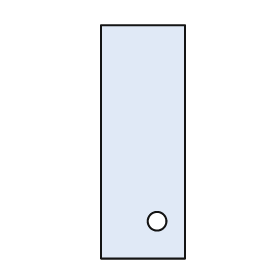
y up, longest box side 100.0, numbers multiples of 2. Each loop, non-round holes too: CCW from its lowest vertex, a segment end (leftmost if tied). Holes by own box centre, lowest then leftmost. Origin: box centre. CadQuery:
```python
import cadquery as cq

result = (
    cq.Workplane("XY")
    .moveTo(-18.0, -50.0)
    .lineTo(18.0, -50.0)
    .lineTo(18.0, 50.0)
    .lineTo(-18.0, 50.0)
    .close()
    .moveTo(6.0, -34.0)
    .circle(4.0)
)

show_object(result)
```